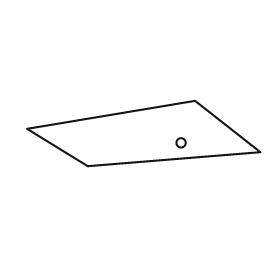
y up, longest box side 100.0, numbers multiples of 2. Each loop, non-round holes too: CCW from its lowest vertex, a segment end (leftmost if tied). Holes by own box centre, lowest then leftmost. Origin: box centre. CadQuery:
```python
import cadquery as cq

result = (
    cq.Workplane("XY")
    .moveTo(-24.0, -14.0)
    .lineTo(50.0, -8.0)
    .lineTo(22.0, 14.0)
    .lineTo(-50.0, 2.0)
    .close()
    .moveTo(16.0, -4.0)
    .circle(2.0)
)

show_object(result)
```